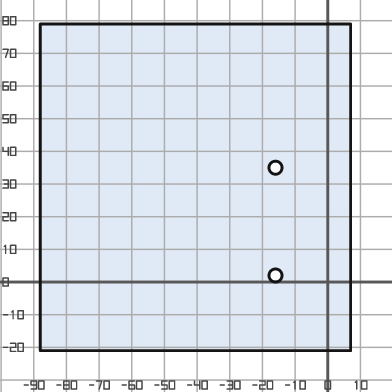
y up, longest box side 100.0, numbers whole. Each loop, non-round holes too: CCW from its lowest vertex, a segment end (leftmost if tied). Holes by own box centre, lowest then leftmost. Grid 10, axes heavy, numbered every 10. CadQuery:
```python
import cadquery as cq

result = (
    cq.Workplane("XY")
    .moveTo(-88.0, -21.0)
    .lineTo(7.0, -21.0)
    .lineTo(7.0, 79.0)
    .lineTo(-88.0, 79.0)
    .close()
    .moveTo(-16.0, 2.0)
    .circle(2.0)
    .moveTo(-16.0, 35.0)
    .circle(2.0)
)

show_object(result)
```